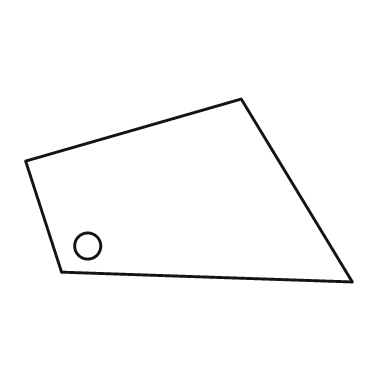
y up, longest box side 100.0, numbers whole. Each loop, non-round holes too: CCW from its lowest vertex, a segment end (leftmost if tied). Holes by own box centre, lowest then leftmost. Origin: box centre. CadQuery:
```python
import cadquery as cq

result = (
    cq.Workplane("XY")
    .moveTo(50.0, -28.0)
    .lineTo(16.0, 28.0)
    .lineTo(-50.0, 9.0)
    .lineTo(-39.0, -25.0)
    .close()
    .moveTo(-31.0, -17.0)
    .circle(4.0)
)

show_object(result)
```